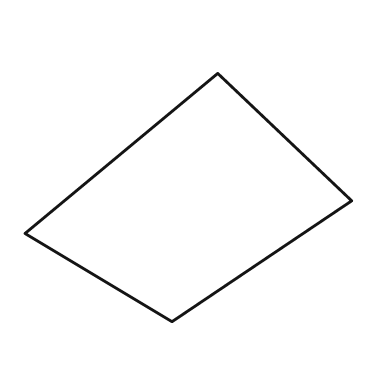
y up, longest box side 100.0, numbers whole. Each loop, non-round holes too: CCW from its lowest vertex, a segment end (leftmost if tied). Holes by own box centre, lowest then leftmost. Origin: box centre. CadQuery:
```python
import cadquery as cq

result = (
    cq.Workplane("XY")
    .moveTo(-5.0, -38.0)
    .lineTo(50.0, -1.0)
    .lineTo(9.0, 38.0)
    .lineTo(-50.0, -11.0)
    .close()
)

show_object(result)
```